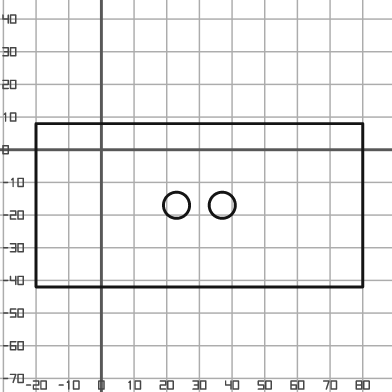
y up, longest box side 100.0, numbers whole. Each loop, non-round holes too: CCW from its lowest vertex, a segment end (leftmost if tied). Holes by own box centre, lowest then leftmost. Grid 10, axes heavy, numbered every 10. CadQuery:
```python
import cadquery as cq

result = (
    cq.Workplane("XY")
    .moveTo(-20.0, -42.0)
    .lineTo(80.0, -42.0)
    .lineTo(80.0, 8.0)
    .lineTo(-20.0, 8.0)
    .close()
    .moveTo(23.0, -17.0)
    .circle(4.0)
    .moveTo(37.0, -17.0)
    .circle(4.0)
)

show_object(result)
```